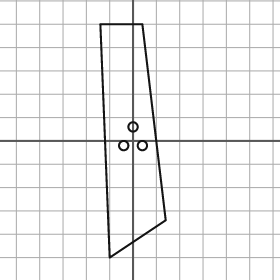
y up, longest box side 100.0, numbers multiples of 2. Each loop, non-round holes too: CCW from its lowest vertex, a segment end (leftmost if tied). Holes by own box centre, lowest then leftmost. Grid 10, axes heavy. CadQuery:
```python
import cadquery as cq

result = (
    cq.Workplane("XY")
    .moveTo(-10.0, -50.0)
    .lineTo(14.0, -34.0)
    .lineTo(4.0, 50.0)
    .lineTo(-14.0, 50.0)
    .close()
    .moveTo(-4.0, -2.0)
    .circle(2.0)
    .moveTo(4.0, -2.0)
    .circle(2.0)
    .moveTo(0.0, 6.0)
    .circle(2.0)
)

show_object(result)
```